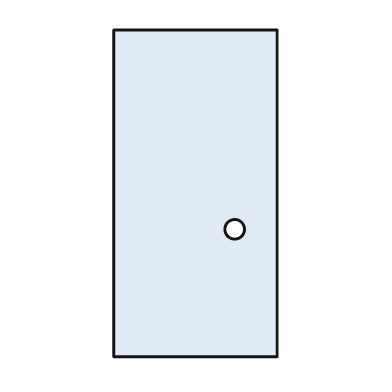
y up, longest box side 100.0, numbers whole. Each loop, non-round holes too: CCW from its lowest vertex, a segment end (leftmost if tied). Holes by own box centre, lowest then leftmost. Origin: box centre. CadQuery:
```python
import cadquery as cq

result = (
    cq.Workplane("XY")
    .moveTo(-25.0, -50.0)
    .lineTo(25.0, -50.0)
    .lineTo(25.0, 50.0)
    .lineTo(-25.0, 50.0)
    .close()
    .moveTo(12.0, -11.0)
    .circle(3.0)
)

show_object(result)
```